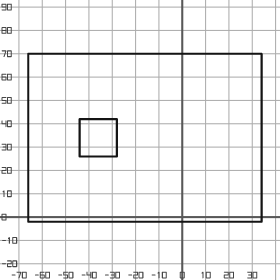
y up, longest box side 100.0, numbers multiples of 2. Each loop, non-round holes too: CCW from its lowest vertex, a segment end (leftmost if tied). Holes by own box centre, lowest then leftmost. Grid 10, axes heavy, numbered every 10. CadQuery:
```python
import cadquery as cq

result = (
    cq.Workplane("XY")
    .moveTo(-66.0, -2.0)
    .lineTo(34.0, -2.0)
    .lineTo(34.0, 70.0)
    .lineTo(-66.0, 70.0)
    .close()
    .moveTo(-44.0, 26.0)
    .lineTo(-28.0, 26.0)
    .lineTo(-28.0, 42.0)
    .lineTo(-44.0, 42.0)
    .close()
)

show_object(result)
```